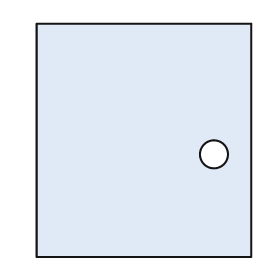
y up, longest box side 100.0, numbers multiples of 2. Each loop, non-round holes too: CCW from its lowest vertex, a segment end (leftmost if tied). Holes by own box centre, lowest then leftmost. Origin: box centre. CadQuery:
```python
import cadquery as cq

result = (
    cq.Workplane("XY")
    .moveTo(-46.0, -50.0)
    .lineTo(46.0, -50.0)
    .lineTo(46.0, 50.0)
    .lineTo(-46.0, 50.0)
    .close()
    .moveTo(30.0, -6.0)
    .circle(6.0)
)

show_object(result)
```